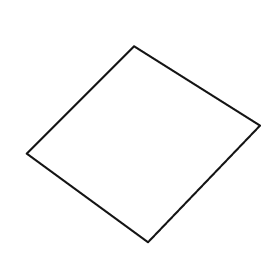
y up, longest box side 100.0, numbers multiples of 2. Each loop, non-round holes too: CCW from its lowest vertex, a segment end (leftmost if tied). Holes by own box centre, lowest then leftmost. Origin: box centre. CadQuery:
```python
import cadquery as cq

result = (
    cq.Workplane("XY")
    .moveTo(2.0, -42.0)
    .lineTo(50.0, 8.0)
    .lineTo(-4.0, 42.0)
    .lineTo(-50.0, -4.0)
    .close()
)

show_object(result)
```